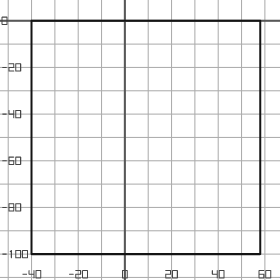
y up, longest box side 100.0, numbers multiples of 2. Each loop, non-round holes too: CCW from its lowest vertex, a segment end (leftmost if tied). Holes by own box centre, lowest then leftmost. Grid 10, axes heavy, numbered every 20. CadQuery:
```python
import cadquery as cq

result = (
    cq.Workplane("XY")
    .moveTo(-40.0, -100.0)
    .lineTo(58.0, -100.0)
    .lineTo(58.0, 0.0)
    .lineTo(-40.0, 0.0)
    .close()
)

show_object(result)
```